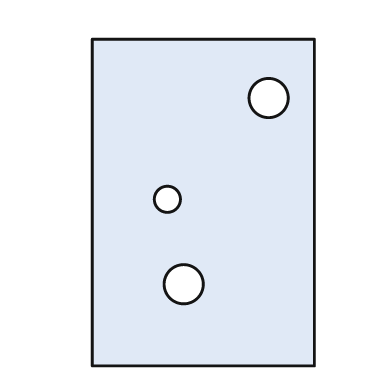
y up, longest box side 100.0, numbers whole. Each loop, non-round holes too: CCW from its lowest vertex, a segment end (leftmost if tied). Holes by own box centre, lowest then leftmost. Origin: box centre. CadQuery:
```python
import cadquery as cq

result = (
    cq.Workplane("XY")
    .moveTo(-34.0, -50.0)
    .lineTo(34.0, -50.0)
    .lineTo(34.0, 50.0)
    .lineTo(-34.0, 50.0)
    .close()
    .moveTo(-6.0, -25.0)
    .circle(6.0)
    .moveTo(-11.0, 1.0)
    .circle(4.0)
    .moveTo(20.0, 32.0)
    .circle(6.0)
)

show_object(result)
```